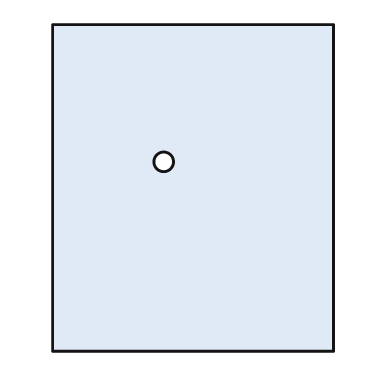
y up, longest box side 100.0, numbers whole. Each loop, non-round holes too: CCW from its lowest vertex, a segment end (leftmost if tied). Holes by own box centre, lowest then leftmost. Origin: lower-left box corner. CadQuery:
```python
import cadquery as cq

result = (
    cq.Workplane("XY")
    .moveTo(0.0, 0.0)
    .lineTo(86.0, 0.0)
    .lineTo(86.0, 100.0)
    .lineTo(0.0, 100.0)
    .close()
    .moveTo(34.0, 58.0)
    .circle(3.0)
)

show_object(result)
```